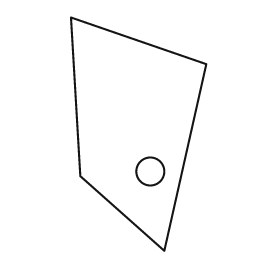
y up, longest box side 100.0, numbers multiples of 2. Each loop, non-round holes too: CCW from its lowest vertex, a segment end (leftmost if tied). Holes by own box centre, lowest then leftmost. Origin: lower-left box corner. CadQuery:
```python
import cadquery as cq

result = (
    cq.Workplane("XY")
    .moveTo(40.0, 0.0)
    .lineTo(58.0, 80.0)
    .lineTo(0.0, 100.0)
    .lineTo(4.0, 32.0)
    .close()
    .moveTo(34.0, 34.0)
    .circle(6.0)
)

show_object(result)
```